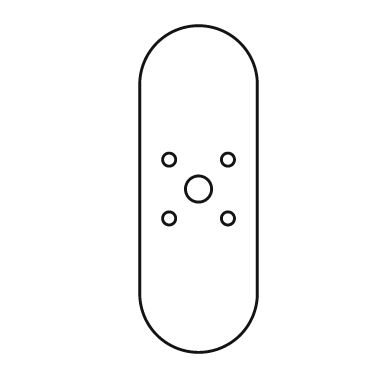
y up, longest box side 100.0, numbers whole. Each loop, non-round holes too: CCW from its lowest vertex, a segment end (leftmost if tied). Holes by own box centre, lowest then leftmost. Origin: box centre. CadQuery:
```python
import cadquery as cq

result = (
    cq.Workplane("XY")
    .moveTo(-18.0, -32.0)
    .threePointArc((0.0, -50.0), (18.0, -32.0))
    .lineTo(18.0, 32.0)
    .threePointArc((0.0, 50.0), (-18.0, 32.0))
    .close()
    .moveTo(-9.0, -9.0)
    .circle(2.0)
    .moveTo(9.0, -9.0)
    .circle(2.0)
    .moveTo(0.0, 0.0)
    .circle(4.0)
    .moveTo(-9.0, 9.0)
    .circle(2.0)
    .moveTo(9.0, 9.0)
    .circle(2.0)
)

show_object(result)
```